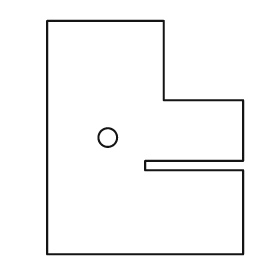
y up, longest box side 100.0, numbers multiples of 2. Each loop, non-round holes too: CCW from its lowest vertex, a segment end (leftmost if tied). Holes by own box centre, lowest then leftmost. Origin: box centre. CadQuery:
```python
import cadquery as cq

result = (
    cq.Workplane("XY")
    .moveTo(-42.0, -50.0)
    .lineTo(42.0, -50.0)
    .lineTo(42.0, -14.0)
    .lineTo(0.0, -14.0)
    .lineTo(0.0, -10.0)
    .lineTo(42.0, -10.0)
    .lineTo(42.0, 16.0)
    .lineTo(8.0, 16.0)
    .lineTo(8.0, 50.0)
    .lineTo(-42.0, 50.0)
    .close()
    .moveTo(-16.0, 0.0)
    .circle(4.0)
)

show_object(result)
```